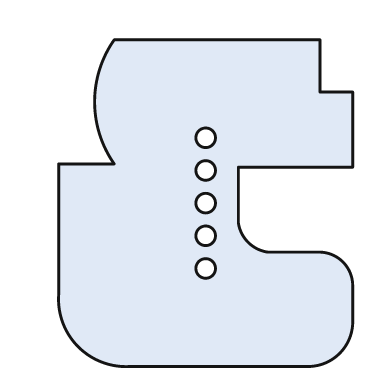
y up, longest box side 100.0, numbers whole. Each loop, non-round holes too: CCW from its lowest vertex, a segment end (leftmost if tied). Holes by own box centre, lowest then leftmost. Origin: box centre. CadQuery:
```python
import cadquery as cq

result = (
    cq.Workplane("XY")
    .moveTo(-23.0, -50.0)
    .lineTo(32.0, -50.0)
    .threePointArc((41.0, -46.0), (45.0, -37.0))
    .lineTo(45.0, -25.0)
    .threePointArc((42.0, -18.0), (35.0, -15.0))
    .lineTo(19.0, -15.0)
    .threePointArc((13.0, -12.0), (10.0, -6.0))
    .lineTo(10.0, 11.0)
    .lineTo(45.0, 11.0)
    .lineTo(45.0, 34.0)
    .lineTo(35.0, 34.0)
    .lineTo(35.0, 50.0)
    .lineTo(-28.0, 50.0)
    .threePointArc((-34.0, 31.0), (-28.0, 12.0))
    .lineTo(-45.0, 12.0)
    .lineTo(-45.0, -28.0)
    .threePointArc((-39.0, -44.0), (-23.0, -50.0))
    .close()
    .moveTo(0.0, -20.0)
    .circle(3.0)
    .moveTo(0.0, -10.0)
    .circle(3.0)
    .moveTo(0.0, 0.0)
    .circle(3.0)
    .moveTo(0.0, 10.0)
    .circle(3.0)
    .moveTo(0.0, 20.0)
    .circle(3.0)
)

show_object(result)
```